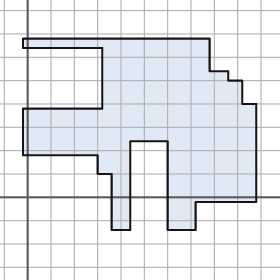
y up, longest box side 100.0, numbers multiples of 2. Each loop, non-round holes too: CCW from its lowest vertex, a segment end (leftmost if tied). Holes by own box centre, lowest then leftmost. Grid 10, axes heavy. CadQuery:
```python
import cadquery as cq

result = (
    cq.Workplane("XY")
    .moveTo(36.0, -14.0)
    .lineTo(44.0, -14.0)
    .lineTo(44.0, 24.0)
    .lineTo(60.0, 24.0)
    .lineTo(60.0, -14.0)
    .lineTo(72.0, -14.0)
    .lineTo(72.0, -2.0)
    .lineTo(98.0, -2.0)
    .lineTo(98.0, 40.0)
    .lineTo(92.0, 40.0)
    .lineTo(92.0, 50.0)
    .lineTo(86.0, 50.0)
    .lineTo(86.0, 54.0)
    .lineTo(78.0, 54.0)
    .lineTo(78.0, 68.0)
    .lineTo(-2.0, 68.0)
    .lineTo(-2.0, 64.0)
    .lineTo(32.0, 64.0)
    .lineTo(32.0, 38.0)
    .lineTo(-2.0, 38.0)
    .lineTo(-2.0, 18.0)
    .lineTo(30.0, 18.0)
    .lineTo(30.0, 10.0)
    .lineTo(36.0, 10.0)
    .close()
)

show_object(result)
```